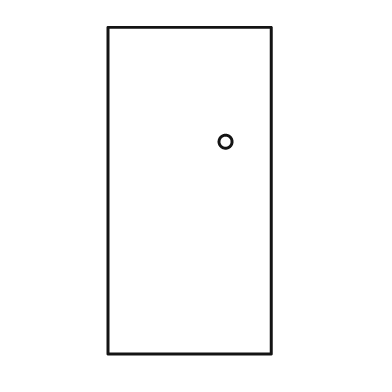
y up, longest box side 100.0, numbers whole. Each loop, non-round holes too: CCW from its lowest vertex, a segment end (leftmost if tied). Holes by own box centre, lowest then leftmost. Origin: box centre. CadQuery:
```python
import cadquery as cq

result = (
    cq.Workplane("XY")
    .moveTo(-25.0, -50.0)
    .lineTo(25.0, -50.0)
    .lineTo(25.0, 50.0)
    .lineTo(-25.0, 50.0)
    .close()
    .moveTo(11.0, 15.0)
    .circle(2.0)
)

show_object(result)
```